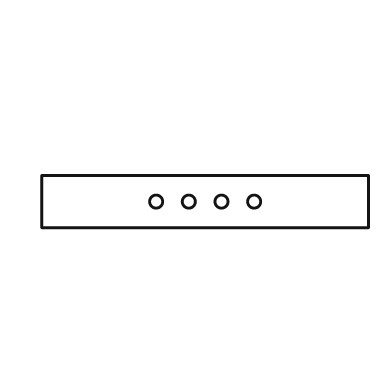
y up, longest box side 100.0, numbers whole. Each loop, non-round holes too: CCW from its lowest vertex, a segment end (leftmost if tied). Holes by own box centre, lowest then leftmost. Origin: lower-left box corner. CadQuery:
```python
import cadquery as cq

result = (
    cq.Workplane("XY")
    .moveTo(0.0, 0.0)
    .lineTo(100.0, 0.0)
    .lineTo(100.0, 16.0)
    .lineTo(0.0, 16.0)
    .close()
    .moveTo(35.0, 8.0)
    .circle(2.0)
    .moveTo(45.0, 8.0)
    .circle(2.0)
    .moveTo(55.0, 8.0)
    .circle(2.0)
    .moveTo(65.0, 8.0)
    .circle(2.0)
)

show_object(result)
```